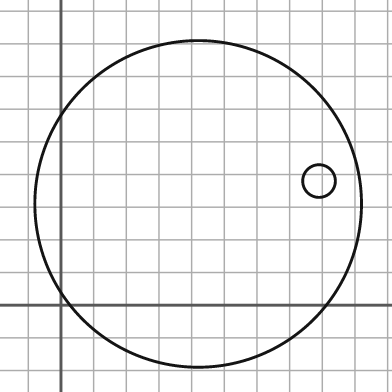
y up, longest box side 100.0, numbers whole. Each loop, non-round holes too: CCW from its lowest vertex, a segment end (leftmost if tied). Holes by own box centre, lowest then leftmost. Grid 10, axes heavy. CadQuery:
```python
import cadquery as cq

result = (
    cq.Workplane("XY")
    .moveTo(42.0, 31.0)
    .circle(50.0)
    .moveTo(79.0, 38.0)
    .circle(5.0)
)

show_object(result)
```